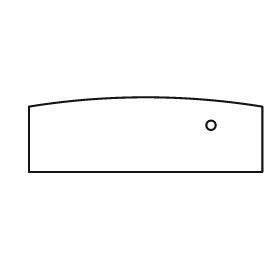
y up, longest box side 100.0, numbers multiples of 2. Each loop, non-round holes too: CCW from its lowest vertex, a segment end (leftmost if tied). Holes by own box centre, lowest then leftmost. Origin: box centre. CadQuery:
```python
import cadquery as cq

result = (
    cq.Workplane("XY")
    .moveTo(-50.0, -16.0)
    .lineTo(50.0, -16.0)
    .lineTo(50.0, 12.0)
    .threePointArc((0.0, 16.0), (-50.0, 12.0))
    .close()
    .moveTo(28.0, 4.0)
    .circle(2.0)
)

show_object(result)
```